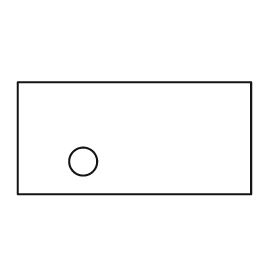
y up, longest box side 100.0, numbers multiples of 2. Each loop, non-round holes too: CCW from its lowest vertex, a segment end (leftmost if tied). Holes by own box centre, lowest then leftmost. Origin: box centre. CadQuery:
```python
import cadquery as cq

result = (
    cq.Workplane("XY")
    .moveTo(-50.0, -24.0)
    .lineTo(50.0, -24.0)
    .lineTo(50.0, 24.0)
    .lineTo(-50.0, 24.0)
    .close()
    .moveTo(-22.0, -10.0)
    .circle(6.0)
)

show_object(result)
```